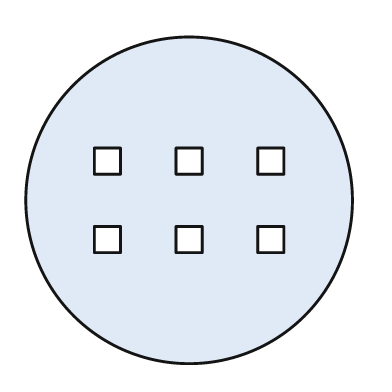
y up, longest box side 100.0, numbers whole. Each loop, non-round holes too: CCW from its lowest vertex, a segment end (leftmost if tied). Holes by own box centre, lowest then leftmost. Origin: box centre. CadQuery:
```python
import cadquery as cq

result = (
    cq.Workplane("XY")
    .moveTo(0.0, 0.0)
    .circle(50.0)
    .moveTo(-29.0, -16.0)
    .lineTo(-21.0, -16.0)
    .lineTo(-21.0, -8.0)
    .lineTo(-29.0, -8.0)
    .close()
    .moveTo(-4.0, -16.0)
    .lineTo(4.0, -16.0)
    .lineTo(4.0, -8.0)
    .lineTo(-4.0, -8.0)
    .close()
    .moveTo(21.0, -16.0)
    .lineTo(29.0, -16.0)
    .lineTo(29.0, -8.0)
    .lineTo(21.0, -8.0)
    .close()
    .moveTo(-29.0, 8.0)
    .lineTo(-21.0, 8.0)
    .lineTo(-21.0, 16.0)
    .lineTo(-29.0, 16.0)
    .close()
    .moveTo(-4.0, 8.0)
    .lineTo(4.0, 8.0)
    .lineTo(4.0, 16.0)
    .lineTo(-4.0, 16.0)
    .close()
    .moveTo(21.0, 8.0)
    .lineTo(29.0, 8.0)
    .lineTo(29.0, 16.0)
    .lineTo(21.0, 16.0)
    .close()
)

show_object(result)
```